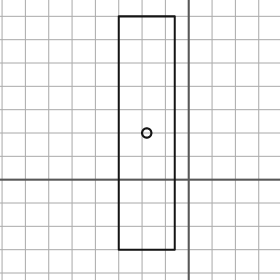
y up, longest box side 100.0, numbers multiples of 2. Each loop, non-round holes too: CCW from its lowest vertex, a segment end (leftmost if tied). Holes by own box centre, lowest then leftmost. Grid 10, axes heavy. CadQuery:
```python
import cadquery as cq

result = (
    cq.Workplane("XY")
    .moveTo(-30.0, -30.0)
    .lineTo(-6.0, -30.0)
    .lineTo(-6.0, 70.0)
    .lineTo(-30.0, 70.0)
    .close()
    .moveTo(-18.0, 20.0)
    .circle(2.0)
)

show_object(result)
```